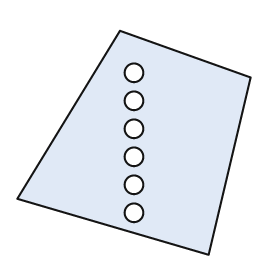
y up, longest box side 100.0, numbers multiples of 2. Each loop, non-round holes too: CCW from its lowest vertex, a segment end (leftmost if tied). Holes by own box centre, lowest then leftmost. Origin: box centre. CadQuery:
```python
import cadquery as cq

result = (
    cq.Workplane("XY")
    .moveTo(32.0, -48.0)
    .lineTo(50.0, 28.0)
    .lineTo(-6.0, 48.0)
    .lineTo(-50.0, -24.0)
    .close()
    .moveTo(0.0, -30.0)
    .circle(4.0)
    .moveTo(0.0, -18.0)
    .circle(4.0)
    .moveTo(0.0, -6.0)
    .circle(4.0)
    .moveTo(0.0, 6.0)
    .circle(4.0)
    .moveTo(0.0, 18.0)
    .circle(4.0)
    .moveTo(0.0, 30.0)
    .circle(4.0)
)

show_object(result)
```